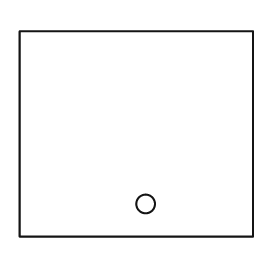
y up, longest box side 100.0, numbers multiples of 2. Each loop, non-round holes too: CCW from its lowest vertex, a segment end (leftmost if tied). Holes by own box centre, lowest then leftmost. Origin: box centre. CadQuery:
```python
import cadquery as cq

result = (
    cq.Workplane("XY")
    .moveTo(-50.0, -44.0)
    .lineTo(50.0, -44.0)
    .lineTo(50.0, 44.0)
    .lineTo(-50.0, 44.0)
    .close()
    .moveTo(4.0, -30.0)
    .circle(4.0)
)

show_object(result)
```